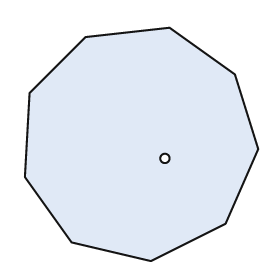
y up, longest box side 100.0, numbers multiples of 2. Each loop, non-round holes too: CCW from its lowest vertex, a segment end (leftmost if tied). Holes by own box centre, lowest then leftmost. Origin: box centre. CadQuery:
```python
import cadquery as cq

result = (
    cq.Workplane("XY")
    .moveTo(4.0, -50.0)
    .lineTo(36.0, -34.0)
    .lineTo(50.0, -2.0)
    .lineTo(40.0, 30.0)
    .lineTo(12.0, 50.0)
    .lineTo(-24.0, 46.0)
    .lineTo(-48.0, 22.0)
    .lineTo(-50.0, -14.0)
    .lineTo(-30.0, -42.0)
    .close()
    .moveTo(10.0, -6.0)
    .circle(2.0)
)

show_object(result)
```